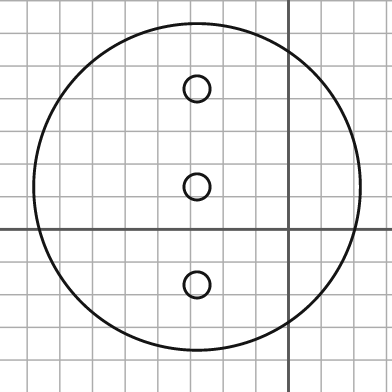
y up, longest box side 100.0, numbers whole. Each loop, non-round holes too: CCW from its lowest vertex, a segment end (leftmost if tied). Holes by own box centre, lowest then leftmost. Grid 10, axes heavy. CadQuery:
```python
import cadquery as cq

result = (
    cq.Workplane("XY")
    .moveTo(-28.0, 13.0)
    .circle(50.0)
    .moveTo(-28.0, -17.0)
    .circle(4.0)
    .moveTo(-28.0, 13.0)
    .circle(4.0)
    .moveTo(-28.0, 43.0)
    .circle(4.0)
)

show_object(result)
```